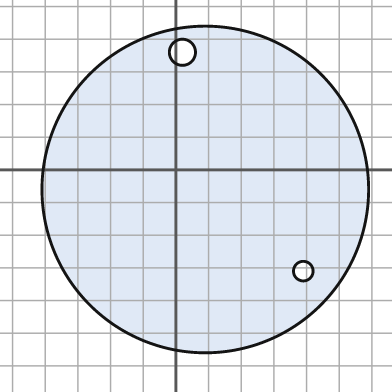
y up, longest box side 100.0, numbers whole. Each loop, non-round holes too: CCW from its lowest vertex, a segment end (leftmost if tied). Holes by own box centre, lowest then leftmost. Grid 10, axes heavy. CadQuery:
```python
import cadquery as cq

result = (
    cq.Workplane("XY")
    .moveTo(9.0, -6.0)
    .circle(50.0)
    .moveTo(39.0, -31.0)
    .circle(3.0)
    .moveTo(2.0, 36.0)
    .circle(4.0)
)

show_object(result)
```